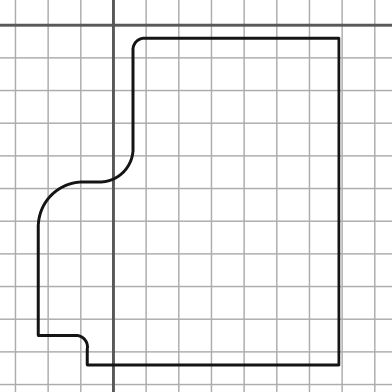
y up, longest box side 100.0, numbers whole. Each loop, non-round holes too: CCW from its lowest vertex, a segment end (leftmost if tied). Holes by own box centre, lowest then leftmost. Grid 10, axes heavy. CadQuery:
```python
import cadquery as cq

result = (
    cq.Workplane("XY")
    .moveTo(-8.0, -104.0)
    .lineTo(69.0, -104.0)
    .lineTo(69.0, -4.0)
    .lineTo(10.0, -4.0)
    .threePointArc((7.0, -5.0), (6.0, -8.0))
    .lineTo(6.0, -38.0)
    .threePointArc((3.0, -45.0), (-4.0, -48.0))
    .lineTo(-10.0, -48.0)
    .threePointArc((-19.0, -52.0), (-23.0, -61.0))
    .lineTo(-23.0, -95.0)
    .lineTo(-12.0, -95.0)
    .threePointArc((-9.0, -96.0), (-8.0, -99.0))
    .close()
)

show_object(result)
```